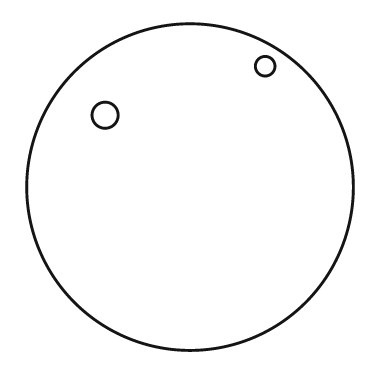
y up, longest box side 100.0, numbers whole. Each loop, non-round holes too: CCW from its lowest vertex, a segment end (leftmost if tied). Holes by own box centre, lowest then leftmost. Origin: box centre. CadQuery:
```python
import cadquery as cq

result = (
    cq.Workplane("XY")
    .moveTo(0.0, 0.0)
    .circle(50.0)
    .moveTo(-26.0, 22.0)
    .circle(4.0)
    .moveTo(23.0, 37.0)
    .circle(3.0)
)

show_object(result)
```